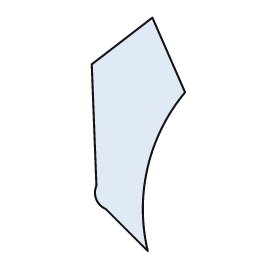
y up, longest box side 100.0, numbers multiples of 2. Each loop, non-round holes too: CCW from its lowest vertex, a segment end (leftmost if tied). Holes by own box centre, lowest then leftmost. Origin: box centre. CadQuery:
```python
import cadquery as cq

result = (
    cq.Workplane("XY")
    .moveTo(4.0, -50.0)
    .threePointArc((4.0, -14.0), (20.0, 18.0))
    .lineTo(6.0, 50.0)
    .lineTo(-20.0, 30.0)
    .lineTo(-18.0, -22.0)
    .threePointArc((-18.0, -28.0), (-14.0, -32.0))
    .close()
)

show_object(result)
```